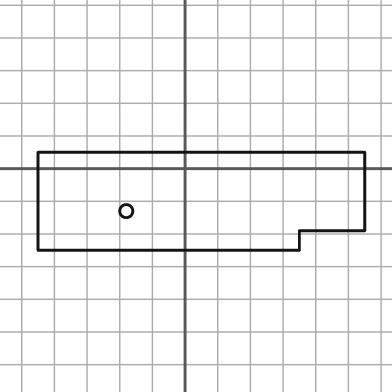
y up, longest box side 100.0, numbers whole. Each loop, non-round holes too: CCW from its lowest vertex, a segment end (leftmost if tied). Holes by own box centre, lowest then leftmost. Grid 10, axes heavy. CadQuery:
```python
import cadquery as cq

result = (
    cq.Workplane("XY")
    .moveTo(-45.0, -25.0)
    .lineTo(35.0, -25.0)
    .lineTo(35.0, -19.0)
    .lineTo(55.0, -19.0)
    .lineTo(55.0, 5.0)
    .lineTo(-45.0, 5.0)
    .close()
    .moveTo(-18.0, -13.0)
    .circle(2.0)
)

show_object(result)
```